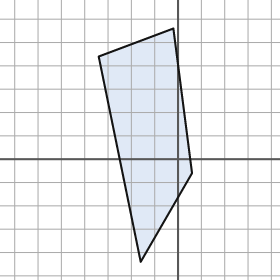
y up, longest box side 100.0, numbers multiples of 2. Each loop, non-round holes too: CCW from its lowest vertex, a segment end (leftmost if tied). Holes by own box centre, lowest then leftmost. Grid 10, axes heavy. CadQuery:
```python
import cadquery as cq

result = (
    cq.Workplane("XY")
    .moveTo(-16.0, -44.0)
    .lineTo(6.0, -6.0)
    .lineTo(-2.0, 56.0)
    .lineTo(-34.0, 44.0)
    .close()
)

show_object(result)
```